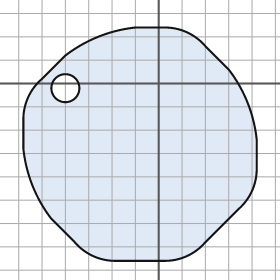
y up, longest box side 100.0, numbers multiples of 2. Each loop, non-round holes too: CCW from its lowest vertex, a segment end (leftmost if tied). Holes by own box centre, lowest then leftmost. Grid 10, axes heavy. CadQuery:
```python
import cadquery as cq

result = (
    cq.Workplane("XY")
    .moveTo(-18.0, -76.0)
    .lineTo(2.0, -76.0)
    .threePointArc((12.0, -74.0), (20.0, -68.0))
    .lineTo(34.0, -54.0)
    .threePointArc((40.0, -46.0), (42.0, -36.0))
    .lineTo(42.0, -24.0)
    .threePointArc((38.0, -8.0), (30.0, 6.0))
    .lineTo(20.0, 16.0)
    .threePointArc((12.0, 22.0), (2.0, 24.0))
    .lineTo(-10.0, 24.0)
    .threePointArc((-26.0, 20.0), (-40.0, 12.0))
    .lineTo(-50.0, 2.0)
    .threePointArc((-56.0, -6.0), (-58.0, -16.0))
    .lineTo(-58.0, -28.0)
    .threePointArc((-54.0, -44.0), (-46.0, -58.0))
    .lineTo(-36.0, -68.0)
    .threePointArc((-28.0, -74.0), (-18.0, -76.0))
    .close()
    .moveTo(-40.0, -2.0)
    .circle(6.0)
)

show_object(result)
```